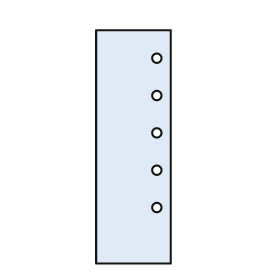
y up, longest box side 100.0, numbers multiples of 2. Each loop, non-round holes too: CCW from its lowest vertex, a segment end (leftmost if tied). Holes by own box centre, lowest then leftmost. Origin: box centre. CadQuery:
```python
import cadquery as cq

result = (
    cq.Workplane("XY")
    .moveTo(-16.0, -50.0)
    .lineTo(16.0, -50.0)
    .lineTo(16.0, 50.0)
    .lineTo(-16.0, 50.0)
    .close()
    .moveTo(10.0, -26.0)
    .circle(2.0)
    .moveTo(10.0, -10.0)
    .circle(2.0)
    .moveTo(10.0, 6.0)
    .circle(2.0)
    .moveTo(10.0, 22.0)
    .circle(2.0)
    .moveTo(10.0, 38.0)
    .circle(2.0)
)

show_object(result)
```